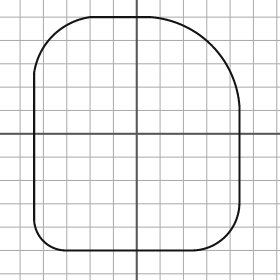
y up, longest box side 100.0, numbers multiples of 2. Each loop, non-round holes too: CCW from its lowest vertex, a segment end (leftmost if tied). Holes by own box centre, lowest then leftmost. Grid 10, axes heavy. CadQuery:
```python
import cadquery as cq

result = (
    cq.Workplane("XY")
    .moveTo(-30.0, -50.0)
    .lineTo(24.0, -50.0)
    .threePointArc((38.0, -44.0), (44.0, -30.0))
    .lineTo(44.0, 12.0)
    .threePointArc((32.0, 38.0), (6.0, 50.0))
    .lineTo(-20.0, 50.0)
    .threePointArc((-36.0, 42.0), (-44.0, 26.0))
    .lineTo(-44.0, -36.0)
    .threePointArc((-40.0, -46.0), (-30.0, -50.0))
    .close()
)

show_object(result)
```